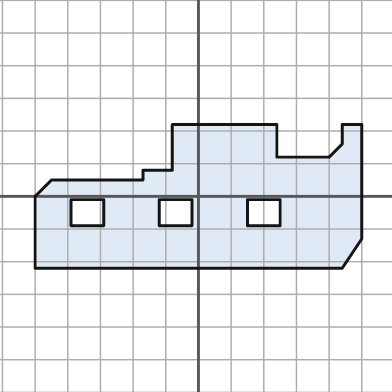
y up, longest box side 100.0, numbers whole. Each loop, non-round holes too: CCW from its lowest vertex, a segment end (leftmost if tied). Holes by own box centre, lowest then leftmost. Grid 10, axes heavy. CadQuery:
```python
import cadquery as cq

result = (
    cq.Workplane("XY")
    .moveTo(-50.0, -22.0)
    .lineTo(44.0, -22.0)
    .lineTo(50.0, -13.0)
    .lineTo(50.0, 22.0)
    .lineTo(44.0, 22.0)
    .lineTo(44.0, 16.0)
    .lineTo(40.0, 12.0)
    .lineTo(24.0, 12.0)
    .lineTo(24.0, 22.0)
    .lineTo(-8.0, 22.0)
    .lineTo(-8.0, 8.0)
    .lineTo(-17.0, 8.0)
    .lineTo(-17.0, 5.0)
    .lineTo(-45.0, 5.0)
    .lineTo(-50.0, 0.0)
    .close()
    .moveTo(-39.0, -9.0)
    .lineTo(-29.0, -9.0)
    .lineTo(-29.0, -1.0)
    .lineTo(-39.0, -1.0)
    .close()
    .moveTo(-12.0, -9.0)
    .lineTo(-2.0, -9.0)
    .lineTo(-2.0, -1.0)
    .lineTo(-12.0, -1.0)
    .close()
    .moveTo(15.0, -9.0)
    .lineTo(25.0, -9.0)
    .lineTo(25.0, -1.0)
    .lineTo(15.0, -1.0)
    .close()
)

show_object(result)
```